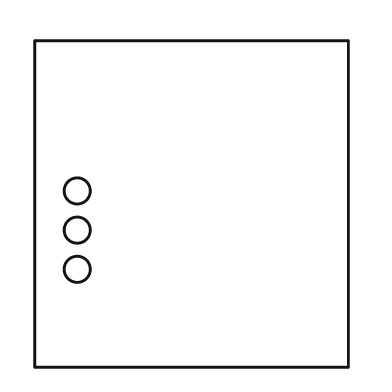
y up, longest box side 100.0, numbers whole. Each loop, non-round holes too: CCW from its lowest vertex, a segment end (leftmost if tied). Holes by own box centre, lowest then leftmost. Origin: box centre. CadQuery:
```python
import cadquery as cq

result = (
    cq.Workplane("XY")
    .moveTo(-48.0, -50.0)
    .lineTo(48.0, -50.0)
    .lineTo(48.0, 50.0)
    .lineTo(-48.0, 50.0)
    .close()
    .moveTo(-35.0, -20.0)
    .circle(4.0)
    .moveTo(-35.0, -8.0)
    .circle(4.0)
    .moveTo(-35.0, 4.0)
    .circle(4.0)
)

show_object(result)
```